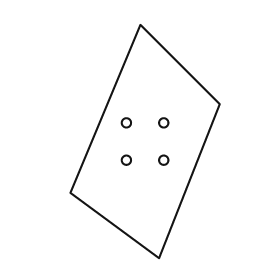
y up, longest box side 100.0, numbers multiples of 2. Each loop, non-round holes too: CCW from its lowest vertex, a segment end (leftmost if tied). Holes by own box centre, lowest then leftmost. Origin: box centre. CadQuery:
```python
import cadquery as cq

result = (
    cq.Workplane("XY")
    .moveTo(6.0, -50.0)
    .lineTo(32.0, 16.0)
    .lineTo(-2.0, 50.0)
    .lineTo(-32.0, -22.0)
    .close()
    .moveTo(-8.0, -8.0)
    .circle(2.0)
    .moveTo(8.0, -8.0)
    .circle(2.0)
    .moveTo(-8.0, 8.0)
    .circle(2.0)
    .moveTo(8.0, 8.0)
    .circle(2.0)
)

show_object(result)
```